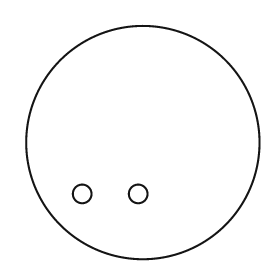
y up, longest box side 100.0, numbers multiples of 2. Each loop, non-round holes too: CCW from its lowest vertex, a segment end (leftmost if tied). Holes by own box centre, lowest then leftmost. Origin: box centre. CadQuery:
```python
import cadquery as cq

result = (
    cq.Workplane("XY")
    .moveTo(0.0, 0.0)
    .circle(50.0)
    .moveTo(-26.0, -22.0)
    .circle(4.0)
    .moveTo(-2.0, -22.0)
    .circle(4.0)
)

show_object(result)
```